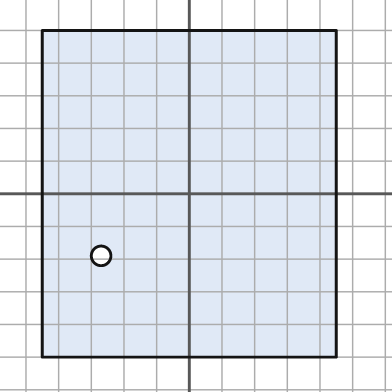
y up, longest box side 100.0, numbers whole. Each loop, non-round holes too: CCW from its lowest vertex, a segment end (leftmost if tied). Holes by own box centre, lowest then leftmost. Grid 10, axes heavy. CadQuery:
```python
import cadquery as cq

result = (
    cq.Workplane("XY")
    .moveTo(-45.0, -50.0)
    .lineTo(45.0, -50.0)
    .lineTo(45.0, 50.0)
    .lineTo(-45.0, 50.0)
    .close()
    .moveTo(-27.0, -19.0)
    .circle(3.0)
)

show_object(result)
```